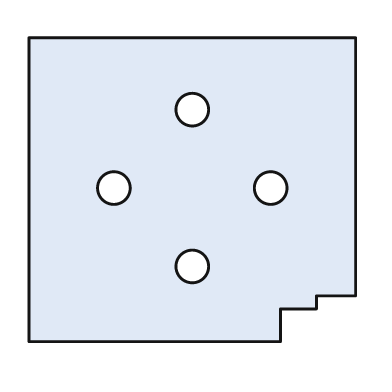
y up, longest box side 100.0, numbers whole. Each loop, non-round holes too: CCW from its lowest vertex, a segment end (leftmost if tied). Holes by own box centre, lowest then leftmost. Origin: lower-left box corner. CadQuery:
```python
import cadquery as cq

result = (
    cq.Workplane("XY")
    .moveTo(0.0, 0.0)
    .lineTo(77.0, 0.0)
    .lineTo(77.0, 10.0)
    .lineTo(88.0, 10.0)
    .lineTo(88.0, 14.0)
    .lineTo(100.0, 14.0)
    .lineTo(100.0, 93.0)
    .lineTo(0.0, 93.0)
    .close()
    .moveTo(50.0, 23.0)
    .circle(5.0)
    .moveTo(26.0, 47.0)
    .circle(5.0)
    .moveTo(74.0, 47.0)
    .circle(5.0)
    .moveTo(50.0, 71.0)
    .circle(5.0)
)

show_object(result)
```